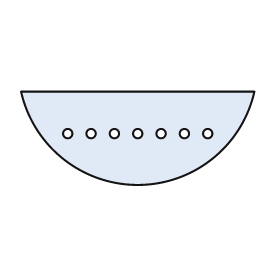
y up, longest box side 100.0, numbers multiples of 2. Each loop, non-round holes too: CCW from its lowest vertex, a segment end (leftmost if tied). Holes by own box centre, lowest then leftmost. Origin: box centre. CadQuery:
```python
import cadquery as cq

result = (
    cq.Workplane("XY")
    .moveTo(-50.0, 20.0)
    .threePointArc((0.0, -20.0), (50.0, 20.0))
    .close()
    .moveTo(-30.0, 2.0)
    .circle(2.0)
    .moveTo(-20.0, 2.0)
    .circle(2.0)
    .moveTo(-10.0, 2.0)
    .circle(2.0)
    .moveTo(0.0, 2.0)
    .circle(2.0)
    .moveTo(10.0, 2.0)
    .circle(2.0)
    .moveTo(20.0, 2.0)
    .circle(2.0)
    .moveTo(30.0, 2.0)
    .circle(2.0)
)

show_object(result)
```